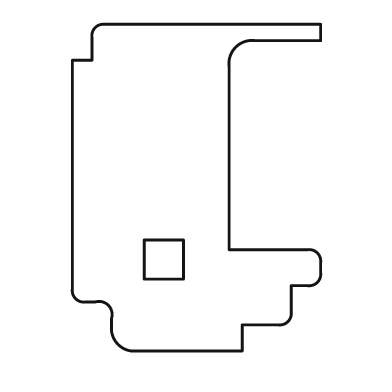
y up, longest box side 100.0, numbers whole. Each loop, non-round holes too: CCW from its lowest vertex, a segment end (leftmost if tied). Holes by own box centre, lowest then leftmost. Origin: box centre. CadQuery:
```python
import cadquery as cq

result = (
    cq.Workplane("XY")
    .moveTo(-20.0, -50.0)
    .lineTo(14.0, -50.0)
    .lineTo(14.0, -42.0)
    .lineTo(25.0, -42.0)
    .threePointArc((28.0, -41.0), (29.0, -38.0))
    .lineTo(29.0, -30.0)
    .lineTo(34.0, -30.0)
    .threePointArc((37.0, -29.0), (38.0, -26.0))
    .lineTo(38.0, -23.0)
    .threePointArc((37.0, -20.0), (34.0, -19.0))
    .lineTo(10.0, -19.0)
    .lineTo(10.0, 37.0)
    .threePointArc((12.0, 43.0), (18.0, 45.0))
    .lineTo(38.0, 45.0)
    .lineTo(38.0, 50.0)
    .lineTo(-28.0, 50.0)
    .threePointArc((-31.0, 49.0), (-32.0, 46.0))
    .lineTo(-32.0, 39.0)
    .lineTo(-38.0, 39.0)
    .lineTo(-38.0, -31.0)
    .threePointArc((-37.0, -34.0), (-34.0, -35.0))
    .lineTo(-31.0, -35.0)
    .threePointArc((-27.0, -36.0), (-26.0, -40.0))
    .lineTo(-26.0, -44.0)
    .threePointArc((-24.0, -48.0), (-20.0, -50.0))
    .close()
    .moveTo(-16.0, -28.0)
    .lineTo(-4.0, -28.0)
    .lineTo(-4.0, -16.0)
    .lineTo(-16.0, -16.0)
    .close()
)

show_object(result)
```